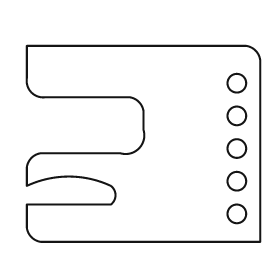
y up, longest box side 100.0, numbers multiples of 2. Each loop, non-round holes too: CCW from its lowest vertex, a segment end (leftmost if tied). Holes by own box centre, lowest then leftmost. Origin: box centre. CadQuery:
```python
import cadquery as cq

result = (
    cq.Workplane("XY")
    .moveTo(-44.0, -42.0)
    .lineTo(50.0, -42.0)
    .lineTo(50.0, 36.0)
    .threePointArc((48.0, 40.0), (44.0, 42.0))
    .lineTo(-50.0, 42.0)
    .lineTo(-50.0, 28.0)
    .threePointArc((-48.0, 22.0), (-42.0, 20.0))
    .lineTo(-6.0, 20.0)
    .threePointArc((-2.0, 18.0), (0.0, 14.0))
    .lineTo(0.0, 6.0)
    .threePointArc((-2.0, -2.0), (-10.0, -4.0))
    .lineTo(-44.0, -4.0)
    .threePointArc((-48.0, -6.0), (-50.0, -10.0))
    .lineTo(-50.0, -18.0)
    .threePointArc((-32.0, -14.0), (-14.0, -18.0))
    .threePointArc((-12.0, -22.0), (-14.0, -26.0))
    .lineTo(-50.0, -26.0)
    .lineTo(-50.0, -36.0)
    .threePointArc((-48.0, -40.0), (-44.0, -42.0))
    .close()
    .moveTo(40.0, -30.0)
    .circle(4.0)
    .moveTo(40.0, -16.0)
    .circle(4.0)
    .moveTo(40.0, -2.0)
    .circle(4.0)
    .moveTo(40.0, 12.0)
    .circle(4.0)
    .moveTo(40.0, 26.0)
    .circle(4.0)
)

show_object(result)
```